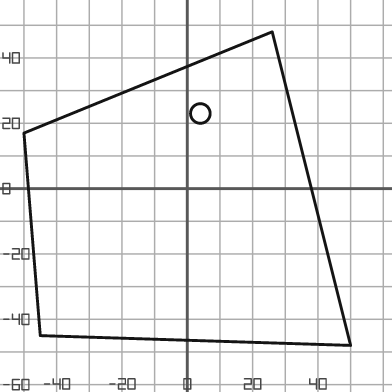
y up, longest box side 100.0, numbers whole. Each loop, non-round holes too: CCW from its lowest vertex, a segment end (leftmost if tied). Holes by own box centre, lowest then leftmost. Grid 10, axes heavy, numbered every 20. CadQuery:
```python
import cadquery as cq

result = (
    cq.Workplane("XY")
    .moveTo(50.0, -48.0)
    .lineTo(26.0, 48.0)
    .lineTo(-50.0, 17.0)
    .lineTo(-45.0, -45.0)
    .close()
    .moveTo(4.0, 23.0)
    .circle(3.0)
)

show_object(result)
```